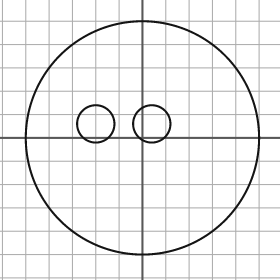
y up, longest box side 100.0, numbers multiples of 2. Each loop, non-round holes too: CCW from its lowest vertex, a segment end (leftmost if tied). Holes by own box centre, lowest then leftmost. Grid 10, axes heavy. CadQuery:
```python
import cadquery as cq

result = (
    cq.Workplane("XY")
    .moveTo(0.0, 0.0)
    .circle(50.0)
    .moveTo(-20.0, 6.0)
    .circle(8.0)
    .moveTo(4.0, 6.0)
    .circle(8.0)
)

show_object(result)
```